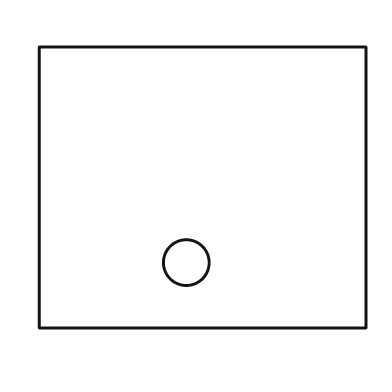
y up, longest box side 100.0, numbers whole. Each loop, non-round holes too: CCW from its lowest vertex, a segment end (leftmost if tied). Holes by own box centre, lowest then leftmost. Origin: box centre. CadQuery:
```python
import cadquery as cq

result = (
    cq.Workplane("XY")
    .moveTo(-50.0, -43.0)
    .lineTo(50.0, -43.0)
    .lineTo(50.0, 43.0)
    .lineTo(-50.0, 43.0)
    .close()
    .moveTo(-5.0, -23.0)
    .circle(7.0)
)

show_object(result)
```